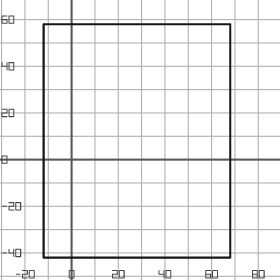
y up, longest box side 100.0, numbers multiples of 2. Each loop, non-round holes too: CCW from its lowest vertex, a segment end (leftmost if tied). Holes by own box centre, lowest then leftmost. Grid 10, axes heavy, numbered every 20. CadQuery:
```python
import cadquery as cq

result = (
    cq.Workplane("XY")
    .moveTo(-12.0, -42.0)
    .lineTo(68.0, -42.0)
    .lineTo(68.0, 58.0)
    .lineTo(-12.0, 58.0)
    .close()
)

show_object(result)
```